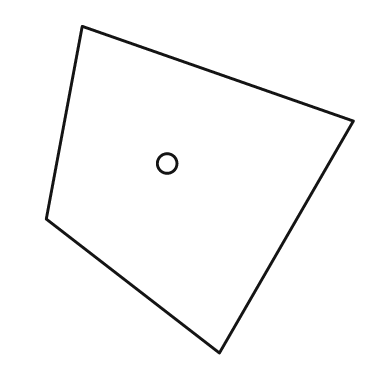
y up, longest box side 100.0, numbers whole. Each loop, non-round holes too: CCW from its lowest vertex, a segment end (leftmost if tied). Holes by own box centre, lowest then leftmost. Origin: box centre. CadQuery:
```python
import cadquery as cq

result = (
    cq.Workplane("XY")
    .moveTo(6.0, -50.0)
    .lineTo(47.0, 21.0)
    .lineTo(-36.0, 50.0)
    .lineTo(-47.0, -9.0)
    .close()
    .moveTo(-10.0, 8.0)
    .circle(3.0)
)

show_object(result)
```